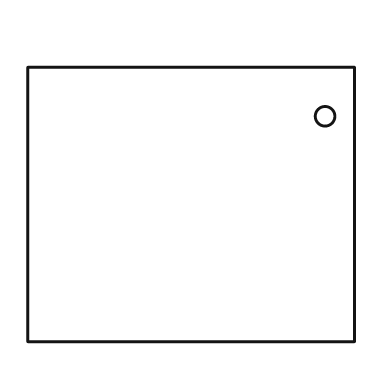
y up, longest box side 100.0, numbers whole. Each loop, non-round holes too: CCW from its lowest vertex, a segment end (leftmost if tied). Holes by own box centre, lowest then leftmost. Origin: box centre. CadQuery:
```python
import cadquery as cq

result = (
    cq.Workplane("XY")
    .moveTo(-50.0, -42.0)
    .lineTo(50.0, -42.0)
    .lineTo(50.0, 42.0)
    .lineTo(-50.0, 42.0)
    .close()
    .moveTo(41.0, 27.0)
    .circle(3.0)
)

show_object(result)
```